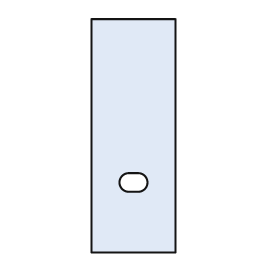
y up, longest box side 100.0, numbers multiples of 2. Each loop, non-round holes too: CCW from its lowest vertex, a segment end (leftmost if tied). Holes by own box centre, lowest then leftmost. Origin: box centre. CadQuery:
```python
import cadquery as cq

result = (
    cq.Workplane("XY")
    .moveTo(-18.0, -50.0)
    .lineTo(18.0, -50.0)
    .lineTo(18.0, 50.0)
    .lineTo(-18.0, 50.0)
    .close()
    .moveTo(-2.0, -24.0)
    .lineTo(2.0, -24.0)
    .threePointArc((6.0, -20.0), (2.0, -16.0))
    .lineTo(-2.0, -16.0)
    .threePointArc((-6.0, -20.0), (-2.0, -24.0))
    .close()
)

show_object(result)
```